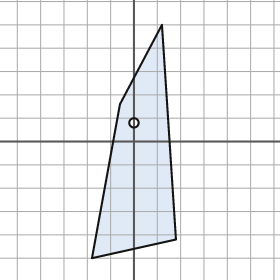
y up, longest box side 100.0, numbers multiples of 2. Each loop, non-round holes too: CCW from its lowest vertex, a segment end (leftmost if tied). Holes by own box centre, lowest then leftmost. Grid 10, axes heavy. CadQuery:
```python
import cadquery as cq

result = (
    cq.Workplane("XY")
    .moveTo(-18.0, -50.0)
    .lineTo(18.0, -42.0)
    .lineTo(12.0, 50.0)
    .lineTo(-6.0, 16.0)
    .close()
    .moveTo(0.0, 8.0)
    .circle(2.0)
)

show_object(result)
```